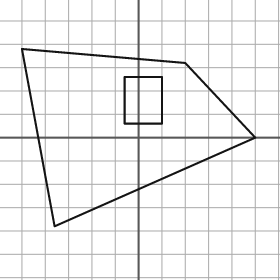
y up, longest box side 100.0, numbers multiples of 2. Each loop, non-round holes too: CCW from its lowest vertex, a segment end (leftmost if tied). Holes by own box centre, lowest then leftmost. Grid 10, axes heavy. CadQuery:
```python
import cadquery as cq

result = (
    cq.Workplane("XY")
    .moveTo(-36.0, -38.0)
    .lineTo(50.0, 0.0)
    .lineTo(20.0, 32.0)
    .lineTo(-50.0, 38.0)
    .close()
    .moveTo(-6.0, 6.0)
    .lineTo(10.0, 6.0)
    .lineTo(10.0, 26.0)
    .lineTo(-6.0, 26.0)
    .close()
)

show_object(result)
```